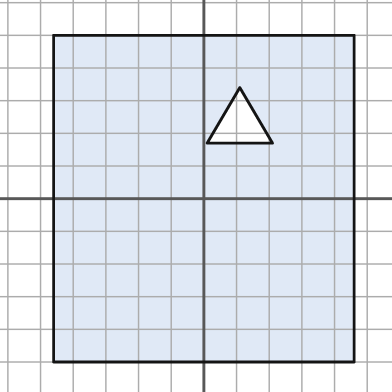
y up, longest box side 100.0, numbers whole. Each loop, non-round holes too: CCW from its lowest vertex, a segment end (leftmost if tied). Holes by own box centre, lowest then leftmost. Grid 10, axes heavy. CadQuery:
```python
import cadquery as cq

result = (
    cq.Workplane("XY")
    .moveTo(-46.0, -50.0)
    .lineTo(46.0, -50.0)
    .lineTo(46.0, 50.0)
    .lineTo(-46.0, 50.0)
    .close()
    .moveTo(1.0, 17.0)
    .lineTo(21.0, 17.0)
    .lineTo(11.0, 34.0)
    .close()
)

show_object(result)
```